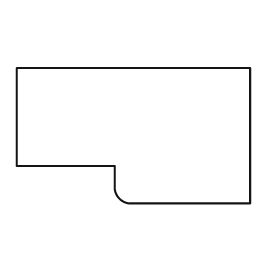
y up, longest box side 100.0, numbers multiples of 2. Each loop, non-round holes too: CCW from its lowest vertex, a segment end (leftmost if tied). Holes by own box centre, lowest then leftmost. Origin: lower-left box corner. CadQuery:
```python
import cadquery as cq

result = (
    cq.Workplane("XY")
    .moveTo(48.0, 0.0)
    .lineTo(100.0, 0.0)
    .lineTo(100.0, 58.0)
    .lineTo(0.0, 58.0)
    .lineTo(0.0, 16.0)
    .lineTo(42.0, 16.0)
    .lineTo(42.0, 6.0)
    .threePointArc((44.0, 2.0), (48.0, 0.0))
    .close()
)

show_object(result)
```